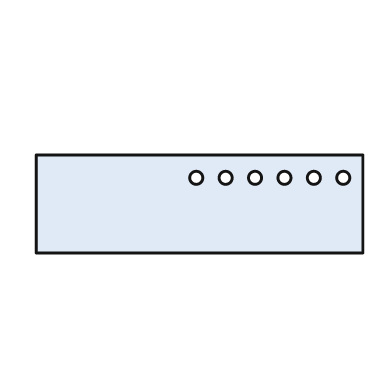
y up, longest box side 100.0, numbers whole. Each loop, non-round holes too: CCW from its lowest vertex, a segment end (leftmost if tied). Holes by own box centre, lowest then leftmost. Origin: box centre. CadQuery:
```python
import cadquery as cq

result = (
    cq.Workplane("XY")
    .moveTo(-50.0, -15.0)
    .lineTo(50.0, -15.0)
    .lineTo(50.0, 15.0)
    .lineTo(-50.0, 15.0)
    .close()
    .moveTo(-1.0, 8.0)
    .circle(2.0)
    .moveTo(8.0, 8.0)
    .circle(2.0)
    .moveTo(17.0, 8.0)
    .circle(2.0)
    .moveTo(26.0, 8.0)
    .circle(2.0)
    .moveTo(35.0, 8.0)
    .circle(2.0)
    .moveTo(44.0, 8.0)
    .circle(2.0)
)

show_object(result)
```